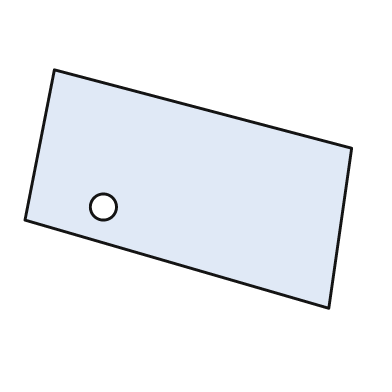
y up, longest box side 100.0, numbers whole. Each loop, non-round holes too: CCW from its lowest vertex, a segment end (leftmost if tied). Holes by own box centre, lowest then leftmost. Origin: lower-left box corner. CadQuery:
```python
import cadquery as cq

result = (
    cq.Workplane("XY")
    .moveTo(93.0, 0.0)
    .lineTo(100.0, 49.0)
    .lineTo(9.0, 73.0)
    .lineTo(0.0, 27.0)
    .close()
    .moveTo(24.0, 31.0)
    .circle(4.0)
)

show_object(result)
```